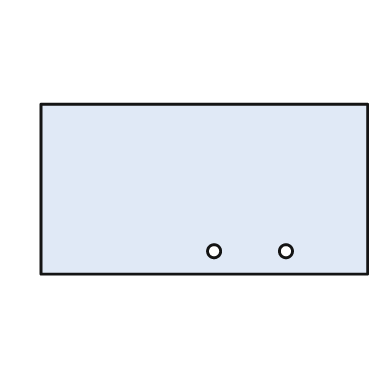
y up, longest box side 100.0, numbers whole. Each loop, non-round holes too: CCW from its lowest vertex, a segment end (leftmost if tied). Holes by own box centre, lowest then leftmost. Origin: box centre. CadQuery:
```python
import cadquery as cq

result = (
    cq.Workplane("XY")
    .moveTo(-50.0, -26.0)
    .lineTo(50.0, -26.0)
    .lineTo(50.0, 26.0)
    .lineTo(-50.0, 26.0)
    .close()
    .moveTo(3.0, -19.0)
    .circle(2.0)
    .moveTo(25.0, -19.0)
    .circle(2.0)
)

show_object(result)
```